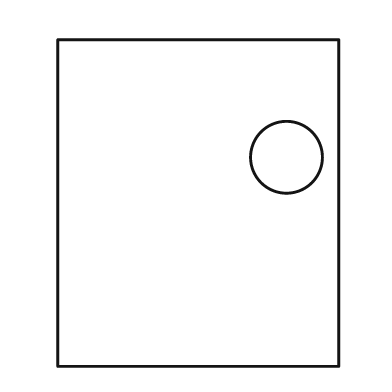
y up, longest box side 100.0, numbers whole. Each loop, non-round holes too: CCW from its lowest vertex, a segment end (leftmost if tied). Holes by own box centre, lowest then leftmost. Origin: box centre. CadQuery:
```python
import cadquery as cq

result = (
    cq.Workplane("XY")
    .moveTo(-43.0, -50.0)
    .lineTo(43.0, -50.0)
    .lineTo(43.0, 50.0)
    .lineTo(-43.0, 50.0)
    .close()
    .moveTo(27.0, 14.0)
    .circle(11.0)
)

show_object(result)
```